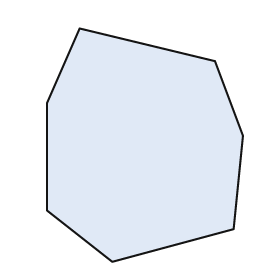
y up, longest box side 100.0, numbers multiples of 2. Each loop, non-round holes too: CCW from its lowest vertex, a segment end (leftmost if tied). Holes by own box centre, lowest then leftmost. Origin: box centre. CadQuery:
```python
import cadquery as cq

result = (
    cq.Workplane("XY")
    .moveTo(-14.0, -50.0)
    .lineTo(38.0, -36.0)
    .lineTo(42.0, 4.0)
    .lineTo(30.0, 36.0)
    .lineTo(-28.0, 50.0)
    .lineTo(-42.0, 18.0)
    .lineTo(-42.0, -28.0)
    .close()
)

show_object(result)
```